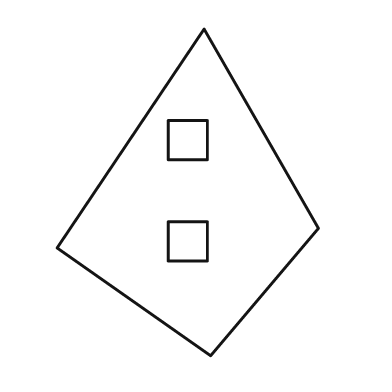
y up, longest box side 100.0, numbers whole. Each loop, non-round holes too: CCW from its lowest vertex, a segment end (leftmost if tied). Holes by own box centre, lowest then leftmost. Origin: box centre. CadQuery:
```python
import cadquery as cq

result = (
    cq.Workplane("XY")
    .moveTo(7.0, -50.0)
    .lineTo(40.0, -11.0)
    .lineTo(5.0, 50.0)
    .lineTo(-40.0, -17.0)
    .close()
    .moveTo(-6.0, -21.0)
    .lineTo(6.0, -21.0)
    .lineTo(6.0, -9.0)
    .lineTo(-6.0, -9.0)
    .close()
    .moveTo(-6.0, 10.0)
    .lineTo(6.0, 10.0)
    .lineTo(6.0, 22.0)
    .lineTo(-6.0, 22.0)
    .close()
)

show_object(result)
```